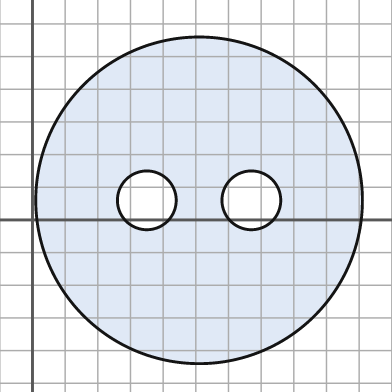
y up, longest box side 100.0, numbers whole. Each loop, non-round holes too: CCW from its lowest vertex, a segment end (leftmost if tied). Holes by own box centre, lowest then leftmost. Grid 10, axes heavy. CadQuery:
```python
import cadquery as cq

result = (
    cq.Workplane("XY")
    .moveTo(51.0, 6.0)
    .circle(50.0)
    .moveTo(35.0, 6.0)
    .circle(9.0)
    .moveTo(67.0, 6.0)
    .circle(9.0)
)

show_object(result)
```